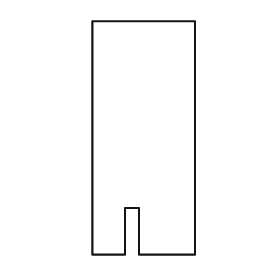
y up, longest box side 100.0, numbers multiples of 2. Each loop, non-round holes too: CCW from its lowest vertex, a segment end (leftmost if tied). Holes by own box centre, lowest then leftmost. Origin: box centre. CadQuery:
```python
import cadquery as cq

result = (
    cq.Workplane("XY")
    .moveTo(-22.0, -50.0)
    .lineTo(-8.0, -50.0)
    .lineTo(-8.0, -30.0)
    .lineTo(-2.0, -30.0)
    .lineTo(-2.0, -50.0)
    .lineTo(22.0, -50.0)
    .lineTo(22.0, 50.0)
    .lineTo(-22.0, 50.0)
    .close()
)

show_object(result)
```